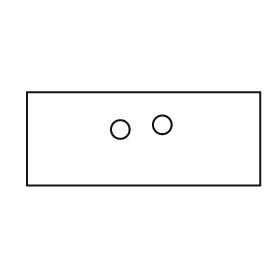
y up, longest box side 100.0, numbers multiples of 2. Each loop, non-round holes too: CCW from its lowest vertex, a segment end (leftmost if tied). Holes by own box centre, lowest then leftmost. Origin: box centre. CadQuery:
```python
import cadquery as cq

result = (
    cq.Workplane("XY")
    .moveTo(-50.0, -20.0)
    .lineTo(50.0, -20.0)
    .lineTo(50.0, 20.0)
    .lineTo(-50.0, 20.0)
    .close()
    .moveTo(-10.0, 4.0)
    .circle(4.0)
    .moveTo(8.0, 6.0)
    .circle(4.0)
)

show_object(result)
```